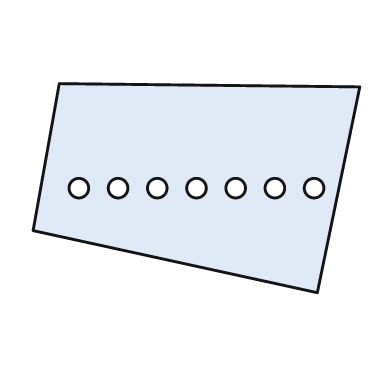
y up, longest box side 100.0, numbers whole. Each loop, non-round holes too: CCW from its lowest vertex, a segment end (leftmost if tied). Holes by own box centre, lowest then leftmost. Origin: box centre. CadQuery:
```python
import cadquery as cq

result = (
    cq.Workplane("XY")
    .moveTo(37.0, -32.0)
    .lineTo(50.0, 31.0)
    .lineTo(-42.0, 32.0)
    .lineTo(-50.0, -13.0)
    .close()
    .moveTo(-36.0, 0.0)
    .circle(3.0)
    .moveTo(-24.0, 0.0)
    .circle(3.0)
    .moveTo(-12.0, 0.0)
    .circle(3.0)
    .moveTo(0.0, 0.0)
    .circle(3.0)
    .moveTo(12.0, 0.0)
    .circle(3.0)
    .moveTo(24.0, 0.0)
    .circle(3.0)
    .moveTo(36.0, 0.0)
    .circle(3.0)
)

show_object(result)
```